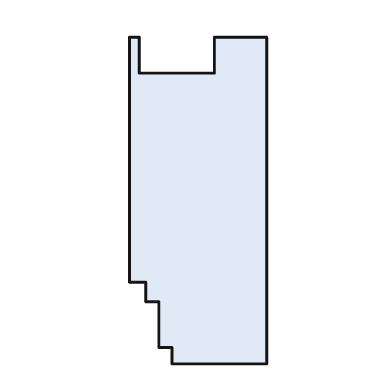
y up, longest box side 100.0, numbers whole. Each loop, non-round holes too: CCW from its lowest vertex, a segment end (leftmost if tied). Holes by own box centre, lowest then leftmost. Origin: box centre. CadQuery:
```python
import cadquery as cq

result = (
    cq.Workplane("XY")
    .moveTo(-8.0, -50.0)
    .lineTo(21.0, -50.0)
    .lineTo(21.0, 50.0)
    .lineTo(5.0, 50.0)
    .lineTo(5.0, 39.0)
    .lineTo(-18.0, 39.0)
    .lineTo(-18.0, 50.0)
    .lineTo(-21.0, 50.0)
    .lineTo(-21.0, -25.0)
    .lineTo(-16.0, -25.0)
    .lineTo(-16.0, -31.0)
    .lineTo(-12.0, -31.0)
    .lineTo(-12.0, -45.0)
    .lineTo(-8.0, -45.0)
    .close()
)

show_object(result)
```